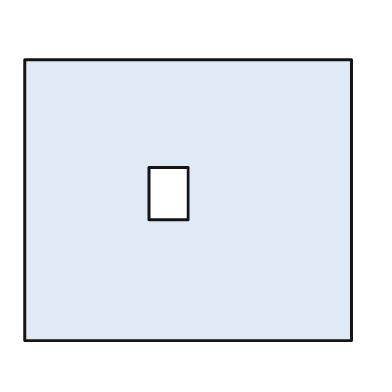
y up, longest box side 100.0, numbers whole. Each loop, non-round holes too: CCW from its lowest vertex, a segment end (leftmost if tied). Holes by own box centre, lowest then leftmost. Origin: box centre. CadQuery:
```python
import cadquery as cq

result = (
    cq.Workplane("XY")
    .moveTo(-50.0, -43.0)
    .lineTo(50.0, -43.0)
    .lineTo(50.0, 43.0)
    .lineTo(-50.0, 43.0)
    .close()
    .moveTo(-12.0, -6.0)
    .lineTo(0.0, -6.0)
    .lineTo(0.0, 10.0)
    .lineTo(-12.0, 10.0)
    .close()
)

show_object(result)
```